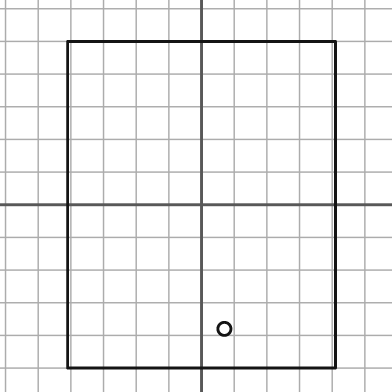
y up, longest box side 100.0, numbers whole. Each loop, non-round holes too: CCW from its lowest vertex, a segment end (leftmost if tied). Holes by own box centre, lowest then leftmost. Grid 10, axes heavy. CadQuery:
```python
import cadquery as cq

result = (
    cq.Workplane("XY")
    .moveTo(-41.0, -50.0)
    .lineTo(41.0, -50.0)
    .lineTo(41.0, 50.0)
    .lineTo(-41.0, 50.0)
    .close()
    .moveTo(7.0, -38.0)
    .circle(2.0)
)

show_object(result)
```